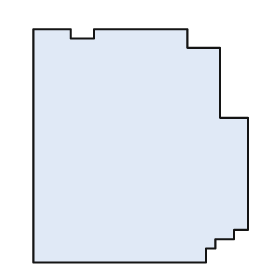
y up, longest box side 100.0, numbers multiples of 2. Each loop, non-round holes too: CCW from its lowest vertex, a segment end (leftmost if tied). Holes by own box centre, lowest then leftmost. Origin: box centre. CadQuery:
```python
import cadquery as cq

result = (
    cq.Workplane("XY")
    .moveTo(-46.0, -50.0)
    .lineTo(28.0, -50.0)
    .lineTo(28.0, -44.0)
    .lineTo(32.0, -44.0)
    .lineTo(32.0, -40.0)
    .lineTo(40.0, -40.0)
    .lineTo(40.0, -36.0)
    .lineTo(46.0, -36.0)
    .lineTo(46.0, 12.0)
    .lineTo(34.0, 12.0)
    .lineTo(34.0, 42.0)
    .lineTo(20.0, 42.0)
    .lineTo(20.0, 50.0)
    .lineTo(-20.0, 50.0)
    .lineTo(-20.0, 46.0)
    .lineTo(-30.0, 46.0)
    .lineTo(-30.0, 50.0)
    .lineTo(-46.0, 50.0)
    .close()
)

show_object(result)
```